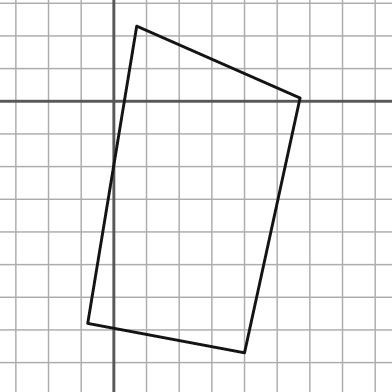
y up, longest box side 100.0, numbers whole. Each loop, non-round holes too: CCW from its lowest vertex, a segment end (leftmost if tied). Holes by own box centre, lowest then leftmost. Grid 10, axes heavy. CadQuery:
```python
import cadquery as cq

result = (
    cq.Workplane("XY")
    .moveTo(40.0, -77.0)
    .lineTo(57.0, 1.0)
    .lineTo(7.0, 23.0)
    .lineTo(-8.0, -68.0)
    .close()
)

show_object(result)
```